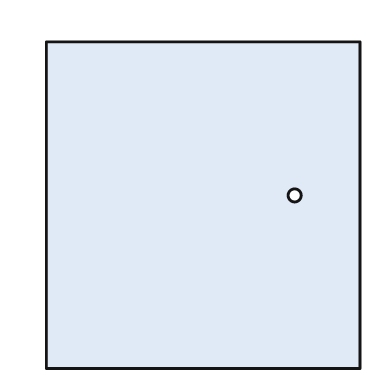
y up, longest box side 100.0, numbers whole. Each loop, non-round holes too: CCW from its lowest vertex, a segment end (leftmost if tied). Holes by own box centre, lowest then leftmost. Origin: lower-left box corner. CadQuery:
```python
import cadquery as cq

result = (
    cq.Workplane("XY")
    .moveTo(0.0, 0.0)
    .lineTo(96.0, 0.0)
    .lineTo(96.0, 100.0)
    .lineTo(0.0, 100.0)
    .close()
    .moveTo(76.0, 53.0)
    .circle(2.0)
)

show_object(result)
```